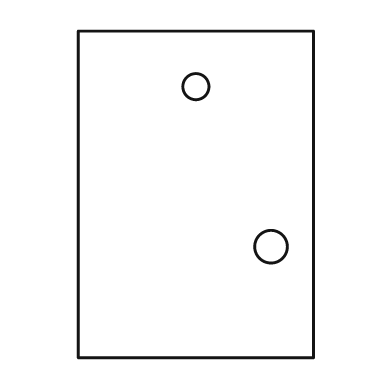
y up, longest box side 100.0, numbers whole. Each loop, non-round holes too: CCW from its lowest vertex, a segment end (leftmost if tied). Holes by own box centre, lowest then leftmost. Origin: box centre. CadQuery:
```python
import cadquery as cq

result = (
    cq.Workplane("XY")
    .moveTo(-36.0, -50.0)
    .lineTo(36.0, -50.0)
    .lineTo(36.0, 50.0)
    .lineTo(-36.0, 50.0)
    .close()
    .moveTo(23.0, -16.0)
    .circle(5.0)
    .moveTo(0.0, 33.0)
    .circle(4.0)
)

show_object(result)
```